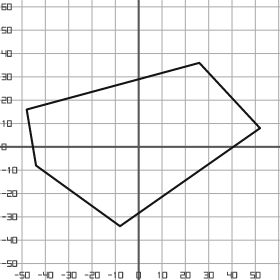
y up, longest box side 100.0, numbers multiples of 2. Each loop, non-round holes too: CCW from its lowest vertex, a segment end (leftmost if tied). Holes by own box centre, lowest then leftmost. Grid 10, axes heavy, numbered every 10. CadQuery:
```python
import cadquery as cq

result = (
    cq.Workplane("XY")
    .moveTo(-8.0, -34.0)
    .lineTo(52.0, 8.0)
    .lineTo(26.0, 36.0)
    .lineTo(-48.0, 16.0)
    .lineTo(-44.0, -8.0)
    .close()
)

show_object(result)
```